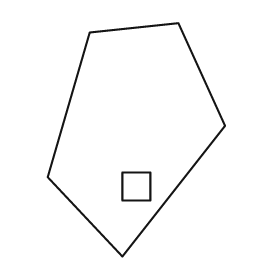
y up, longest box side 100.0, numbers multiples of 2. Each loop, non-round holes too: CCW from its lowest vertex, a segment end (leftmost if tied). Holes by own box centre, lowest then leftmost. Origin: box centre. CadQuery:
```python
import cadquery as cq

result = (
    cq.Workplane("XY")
    .moveTo(-6.0, -50.0)
    .lineTo(38.0, 6.0)
    .lineTo(18.0, 50.0)
    .lineTo(-20.0, 46.0)
    .lineTo(-38.0, -16.0)
    .close()
    .moveTo(-6.0, -26.0)
    .lineTo(6.0, -26.0)
    .lineTo(6.0, -14.0)
    .lineTo(-6.0, -14.0)
    .close()
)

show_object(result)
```